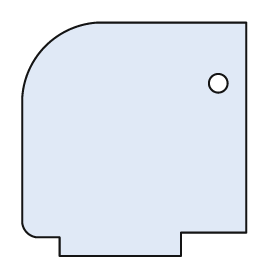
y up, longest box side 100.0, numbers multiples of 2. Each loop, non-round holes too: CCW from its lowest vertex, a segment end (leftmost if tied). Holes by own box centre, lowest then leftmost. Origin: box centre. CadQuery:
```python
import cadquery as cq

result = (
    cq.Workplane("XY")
    .moveTo(-32.0, -50.0)
    .lineTo(20.0, -50.0)
    .lineTo(20.0, -40.0)
    .lineTo(48.0, -40.0)
    .lineTo(48.0, 50.0)
    .lineTo(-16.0, 50.0)
    .threePointArc((-38.0, 40.0), (-48.0, 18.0))
    .lineTo(-48.0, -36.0)
    .threePointArc((-46.0, -40.0), (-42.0, -42.0))
    .lineTo(-32.0, -42.0)
    .close()
    .moveTo(36.0, 24.0)
    .circle(4.0)
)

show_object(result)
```